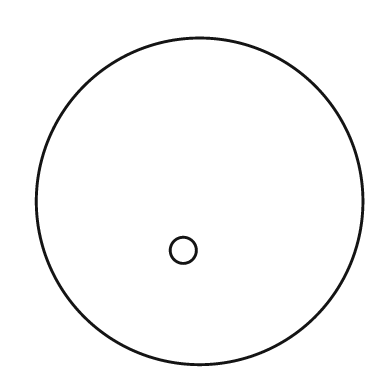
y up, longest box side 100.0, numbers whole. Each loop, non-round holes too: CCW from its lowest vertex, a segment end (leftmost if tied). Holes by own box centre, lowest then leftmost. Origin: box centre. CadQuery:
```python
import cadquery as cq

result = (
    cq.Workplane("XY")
    .moveTo(0.0, 0.0)
    .circle(50.0)
    .moveTo(-5.0, -15.0)
    .circle(4.0)
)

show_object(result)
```